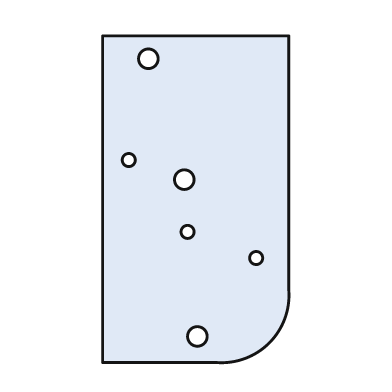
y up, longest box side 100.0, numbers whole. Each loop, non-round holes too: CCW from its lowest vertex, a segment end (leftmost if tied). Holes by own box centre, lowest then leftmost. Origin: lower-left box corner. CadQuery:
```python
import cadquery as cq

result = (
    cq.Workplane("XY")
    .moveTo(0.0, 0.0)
    .lineTo(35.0, 0.0)
    .threePointArc((51.0, 6.0), (57.0, 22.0))
    .lineTo(57.0, 100.0)
    .lineTo(0.0, 100.0)
    .close()
    .moveTo(29.0, 8.0)
    .circle(3.0)
    .moveTo(47.0, 32.0)
    .circle(2.0)
    .moveTo(26.0, 40.0)
    .circle(2.0)
    .moveTo(25.0, 56.0)
    .circle(3.0)
    .moveTo(8.0, 62.0)
    .circle(2.0)
    .moveTo(14.0, 93.0)
    .circle(3.0)
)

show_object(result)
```